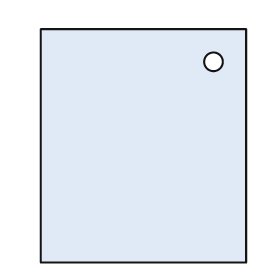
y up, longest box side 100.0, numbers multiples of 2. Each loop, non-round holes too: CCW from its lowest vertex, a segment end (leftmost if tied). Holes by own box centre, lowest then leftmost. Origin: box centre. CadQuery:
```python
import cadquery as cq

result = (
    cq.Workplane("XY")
    .moveTo(-44.0, -50.0)
    .lineTo(44.0, -50.0)
    .lineTo(44.0, 50.0)
    .lineTo(-44.0, 50.0)
    .close()
    .moveTo(30.0, 36.0)
    .circle(4.0)
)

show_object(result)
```